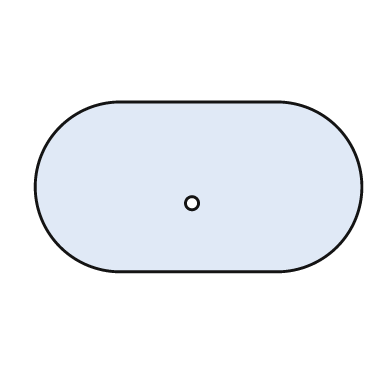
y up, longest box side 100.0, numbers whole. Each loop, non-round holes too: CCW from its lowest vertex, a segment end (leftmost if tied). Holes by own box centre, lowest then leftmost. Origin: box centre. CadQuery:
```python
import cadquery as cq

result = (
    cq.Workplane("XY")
    .moveTo(-24.0, -26.0)
    .lineTo(24.0, -26.0)
    .threePointArc((50.0, 0.0), (24.0, 26.0))
    .lineTo(-24.0, 26.0)
    .threePointArc((-50.0, 0.0), (-24.0, -26.0))
    .close()
    .moveTo(-2.0, -5.0)
    .circle(2.0)
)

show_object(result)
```